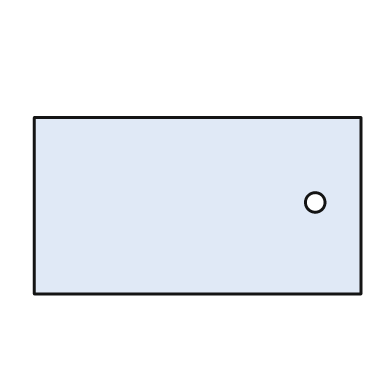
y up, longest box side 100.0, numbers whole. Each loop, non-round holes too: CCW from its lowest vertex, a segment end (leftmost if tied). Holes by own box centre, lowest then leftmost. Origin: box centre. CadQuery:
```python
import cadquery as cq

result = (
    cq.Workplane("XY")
    .moveTo(-50.0, -27.0)
    .lineTo(50.0, -27.0)
    .lineTo(50.0, 27.0)
    .lineTo(-50.0, 27.0)
    .close()
    .moveTo(36.0, 1.0)
    .circle(3.0)
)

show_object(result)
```